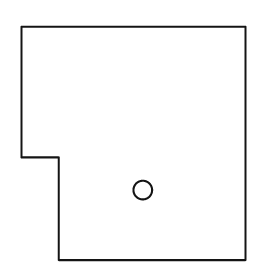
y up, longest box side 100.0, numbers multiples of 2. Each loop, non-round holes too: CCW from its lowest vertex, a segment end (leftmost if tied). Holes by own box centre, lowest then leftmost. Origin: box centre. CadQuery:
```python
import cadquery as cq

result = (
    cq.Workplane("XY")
    .moveTo(-32.0, -50.0)
    .lineTo(48.0, -50.0)
    .lineTo(48.0, 50.0)
    .lineTo(-48.0, 50.0)
    .lineTo(-48.0, -6.0)
    .lineTo(-32.0, -6.0)
    .close()
    .moveTo(4.0, -20.0)
    .circle(4.0)
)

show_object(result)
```